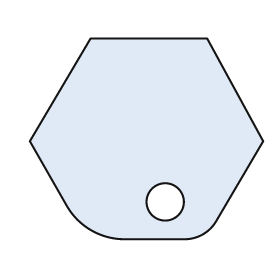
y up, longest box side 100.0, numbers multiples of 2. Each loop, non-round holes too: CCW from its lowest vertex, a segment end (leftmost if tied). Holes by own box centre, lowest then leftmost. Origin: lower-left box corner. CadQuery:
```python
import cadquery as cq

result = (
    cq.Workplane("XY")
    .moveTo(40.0, 0.0)
    .lineTo(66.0, 0.0)
    .threePointArc((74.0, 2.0), (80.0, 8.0))
    .lineTo(100.0, 42.0)
    .lineTo(76.0, 86.0)
    .lineTo(26.0, 86.0)
    .lineTo(0.0, 42.0)
    .lineTo(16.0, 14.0)
    .threePointArc((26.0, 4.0), (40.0, 0.0))
    .close()
    .moveTo(58.0, 16.0)
    .circle(8.0)
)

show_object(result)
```